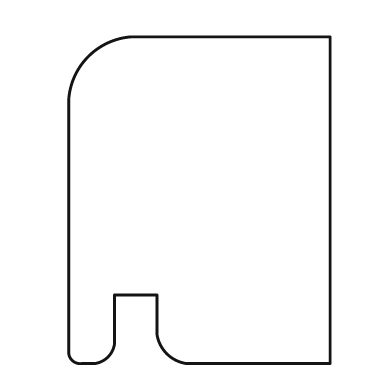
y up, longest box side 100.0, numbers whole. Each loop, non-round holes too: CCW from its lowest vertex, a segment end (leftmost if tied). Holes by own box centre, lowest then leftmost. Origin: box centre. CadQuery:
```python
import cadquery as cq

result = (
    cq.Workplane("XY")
    .moveTo(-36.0, -50.0)
    .lineTo(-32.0, -50.0)
    .threePointArc((-28.0, -48.0), (-26.0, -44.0))
    .lineTo(-26.0, -29.0)
    .lineTo(-13.0, -29.0)
    .lineTo(-13.0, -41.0)
    .threePointArc((-10.0, -47.0), (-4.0, -50.0))
    .lineTo(40.0, -50.0)
    .lineTo(40.0, 50.0)
    .lineTo(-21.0, 50.0)
    .threePointArc((-34.0, 44.0), (-40.0, 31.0))
    .lineTo(-40.0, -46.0)
    .threePointArc((-39.0, -49.0), (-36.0, -50.0))
    .close()
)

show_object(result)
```